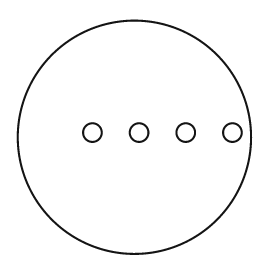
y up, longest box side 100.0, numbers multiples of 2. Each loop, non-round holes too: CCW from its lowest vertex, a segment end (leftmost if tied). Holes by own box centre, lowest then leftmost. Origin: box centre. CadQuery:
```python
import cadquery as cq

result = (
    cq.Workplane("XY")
    .moveTo(0.0, 0.0)
    .circle(50.0)
    .moveTo(-18.0, 2.0)
    .circle(4.0)
    .moveTo(2.0, 2.0)
    .circle(4.0)
    .moveTo(22.0, 2.0)
    .circle(4.0)
    .moveTo(42.0, 2.0)
    .circle(4.0)
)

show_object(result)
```